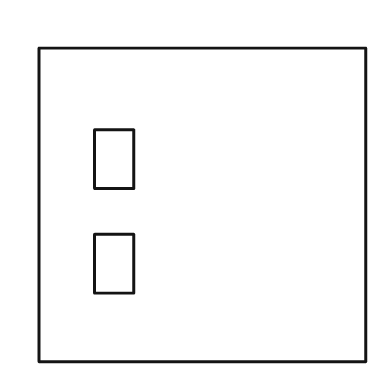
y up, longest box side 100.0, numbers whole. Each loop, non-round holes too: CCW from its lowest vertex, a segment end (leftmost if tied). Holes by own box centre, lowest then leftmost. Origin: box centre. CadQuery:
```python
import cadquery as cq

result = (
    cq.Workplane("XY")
    .moveTo(-50.0, -48.0)
    .lineTo(50.0, -48.0)
    .lineTo(50.0, 48.0)
    .lineTo(-50.0, 48.0)
    .close()
    .moveTo(-33.0, -27.0)
    .lineTo(-21.0, -27.0)
    .lineTo(-21.0, -9.0)
    .lineTo(-33.0, -9.0)
    .close()
    .moveTo(-33.0, 5.0)
    .lineTo(-21.0, 5.0)
    .lineTo(-21.0, 23.0)
    .lineTo(-33.0, 23.0)
    .close()
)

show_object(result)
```